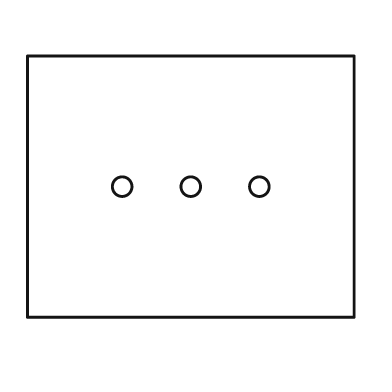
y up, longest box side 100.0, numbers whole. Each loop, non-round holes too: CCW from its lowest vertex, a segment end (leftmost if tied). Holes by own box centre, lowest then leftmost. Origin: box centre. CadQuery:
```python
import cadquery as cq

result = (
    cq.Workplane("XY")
    .moveTo(-50.0, -40.0)
    .lineTo(50.0, -40.0)
    .lineTo(50.0, 40.0)
    .lineTo(-50.0, 40.0)
    .close()
    .moveTo(-21.0, 0.0)
    .circle(3.0)
    .moveTo(0.0, 0.0)
    .circle(3.0)
    .moveTo(21.0, 0.0)
    .circle(3.0)
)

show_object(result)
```